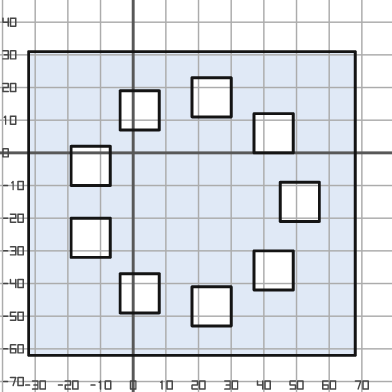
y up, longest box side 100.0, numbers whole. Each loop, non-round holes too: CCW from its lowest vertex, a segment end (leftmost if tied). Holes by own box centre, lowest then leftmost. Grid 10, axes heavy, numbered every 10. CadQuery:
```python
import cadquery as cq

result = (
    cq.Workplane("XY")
    .moveTo(-32.0, -62.0)
    .lineTo(68.0, -62.0)
    .lineTo(68.0, 31.0)
    .lineTo(-32.0, 31.0)
    .close()
    .moveTo(18.0, -53.0)
    .lineTo(30.0, -53.0)
    .lineTo(30.0, -41.0)
    .lineTo(18.0, -41.0)
    .close()
    .moveTo(-4.0, -49.0)
    .lineTo(8.0, -49.0)
    .lineTo(8.0, -37.0)
    .lineTo(-4.0, -37.0)
    .close()
    .moveTo(37.0, -42.0)
    .lineTo(49.0, -42.0)
    .lineTo(49.0, -30.0)
    .lineTo(37.0, -30.0)
    .close()
    .moveTo(-19.0, -32.0)
    .lineTo(-7.0, -32.0)
    .lineTo(-7.0, -20.0)
    .lineTo(-19.0, -20.0)
    .close()
    .moveTo(45.0, -21.0)
    .lineTo(57.0, -21.0)
    .lineTo(57.0, -9.0)
    .lineTo(45.0, -9.0)
    .close()
    .moveTo(-19.0, -10.0)
    .lineTo(-7.0, -10.0)
    .lineTo(-7.0, 2.0)
    .lineTo(-19.0, 2.0)
    .close()
    .moveTo(37.0, 0.0)
    .lineTo(49.0, 0.0)
    .lineTo(49.0, 12.0)
    .lineTo(37.0, 12.0)
    .close()
    .moveTo(-4.0, 7.0)
    .lineTo(8.0, 7.0)
    .lineTo(8.0, 19.0)
    .lineTo(-4.0, 19.0)
    .close()
    .moveTo(18.0, 11.0)
    .lineTo(30.0, 11.0)
    .lineTo(30.0, 23.0)
    .lineTo(18.0, 23.0)
    .close()
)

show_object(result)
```